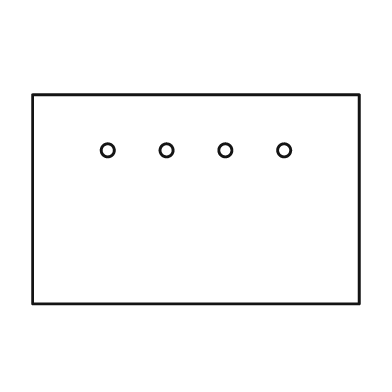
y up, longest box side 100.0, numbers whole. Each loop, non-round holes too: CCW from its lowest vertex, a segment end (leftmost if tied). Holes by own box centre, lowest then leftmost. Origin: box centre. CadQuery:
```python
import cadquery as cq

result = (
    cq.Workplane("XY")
    .moveTo(-50.0, -32.0)
    .lineTo(50.0, -32.0)
    .lineTo(50.0, 32.0)
    .lineTo(-50.0, 32.0)
    .close()
    .moveTo(-27.0, 15.0)
    .circle(2.0)
    .moveTo(-9.0, 15.0)
    .circle(2.0)
    .moveTo(9.0, 15.0)
    .circle(2.0)
    .moveTo(27.0, 15.0)
    .circle(2.0)
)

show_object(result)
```